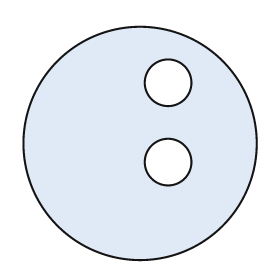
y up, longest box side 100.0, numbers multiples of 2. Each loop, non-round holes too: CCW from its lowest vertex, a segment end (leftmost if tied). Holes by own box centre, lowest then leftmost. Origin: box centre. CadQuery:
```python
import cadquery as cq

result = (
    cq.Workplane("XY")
    .moveTo(0.0, 0.0)
    .circle(50.0)
    .moveTo(12.0, -8.0)
    .circle(10.0)
    .moveTo(12.0, 26.0)
    .circle(10.0)
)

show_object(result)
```